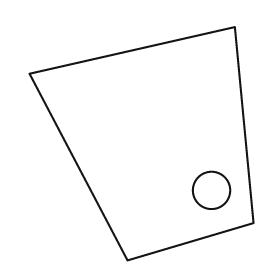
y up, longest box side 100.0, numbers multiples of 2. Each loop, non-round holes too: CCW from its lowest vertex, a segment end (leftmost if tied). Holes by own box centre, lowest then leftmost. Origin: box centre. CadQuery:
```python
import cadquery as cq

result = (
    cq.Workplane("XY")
    .moveTo(-6.0, -50.0)
    .lineTo(48.0, -34.0)
    .lineTo(40.0, 50.0)
    .lineTo(-48.0, 30.0)
    .close()
    .moveTo(30.0, -20.0)
    .circle(8.0)
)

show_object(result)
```